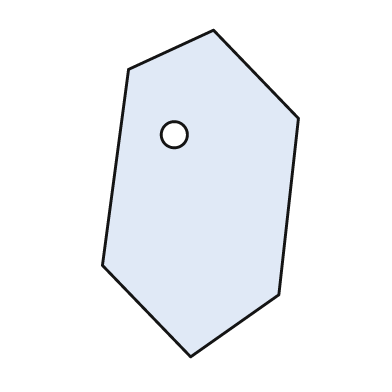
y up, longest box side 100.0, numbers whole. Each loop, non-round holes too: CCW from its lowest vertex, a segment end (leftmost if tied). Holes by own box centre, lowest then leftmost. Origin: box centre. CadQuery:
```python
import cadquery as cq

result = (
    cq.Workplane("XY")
    .moveTo(-3.0, -50.0)
    .lineTo(24.0, -31.0)
    .lineTo(30.0, 23.0)
    .lineTo(4.0, 50.0)
    .lineTo(-22.0, 38.0)
    .lineTo(-30.0, -22.0)
    .close()
    .moveTo(-8.0, 18.0)
    .circle(4.0)
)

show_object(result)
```